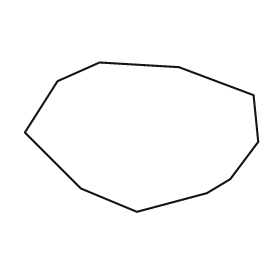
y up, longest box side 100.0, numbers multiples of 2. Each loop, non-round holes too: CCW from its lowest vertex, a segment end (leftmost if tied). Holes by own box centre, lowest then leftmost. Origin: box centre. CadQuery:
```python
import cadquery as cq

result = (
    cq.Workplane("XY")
    .moveTo(-2.0, -32.0)
    .lineTo(28.0, -24.0)
    .lineTo(38.0, -18.0)
    .lineTo(50.0, -2.0)
    .lineTo(48.0, 18.0)
    .lineTo(16.0, 30.0)
    .lineTo(-18.0, 32.0)
    .lineTo(-36.0, 24.0)
    .lineTo(-50.0, 2.0)
    .lineTo(-26.0, -22.0)
    .close()
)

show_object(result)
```